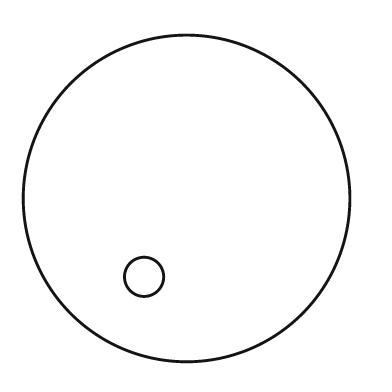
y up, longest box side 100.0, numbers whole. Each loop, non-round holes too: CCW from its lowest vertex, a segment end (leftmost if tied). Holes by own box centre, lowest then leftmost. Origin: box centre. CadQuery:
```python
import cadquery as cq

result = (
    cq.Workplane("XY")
    .moveTo(0.0, 0.0)
    .circle(50.0)
    .moveTo(-13.0, -24.0)
    .circle(6.0)
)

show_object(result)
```